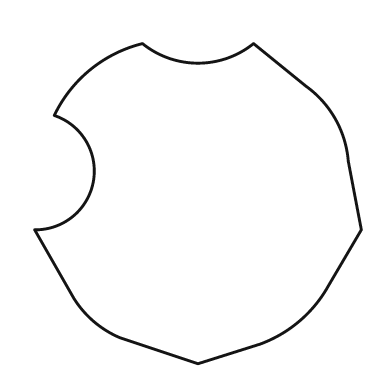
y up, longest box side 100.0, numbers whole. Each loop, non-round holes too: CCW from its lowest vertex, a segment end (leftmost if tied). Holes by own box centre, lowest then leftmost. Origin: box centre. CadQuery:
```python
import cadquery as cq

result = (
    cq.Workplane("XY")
    .moveTo(0.0, -49.0)
    .lineTo(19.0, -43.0)
    .threePointArc((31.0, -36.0), (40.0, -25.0))
    .lineTo(50.0, -8.0)
    .lineTo(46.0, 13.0)
    .threePointArc((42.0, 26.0), (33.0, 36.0))
    .lineTo(17.0, 49.0)
    .threePointArc((0.0, 43.0), (-17.0, 49.0))
    .threePointArc((-33.0, 41.0), (-44.0, 27.0))
    .threePointArc((-32.0, 7.0), (-50.0, -8.0))
    .lineTo(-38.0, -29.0)
    .threePointArc((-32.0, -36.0), (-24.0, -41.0))
    .close()
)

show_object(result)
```